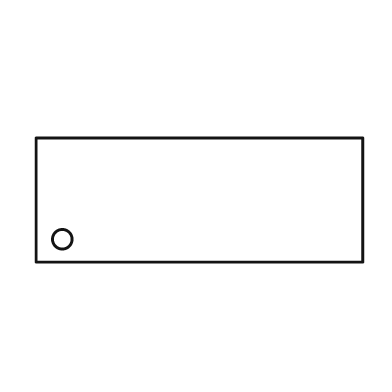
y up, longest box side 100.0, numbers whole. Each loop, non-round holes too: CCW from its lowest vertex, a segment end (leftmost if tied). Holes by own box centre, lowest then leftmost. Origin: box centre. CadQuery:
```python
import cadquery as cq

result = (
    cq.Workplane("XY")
    .moveTo(-50.0, -19.0)
    .lineTo(50.0, -19.0)
    .lineTo(50.0, 19.0)
    .lineTo(-50.0, 19.0)
    .close()
    .moveTo(-42.0, -12.0)
    .circle(3.0)
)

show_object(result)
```